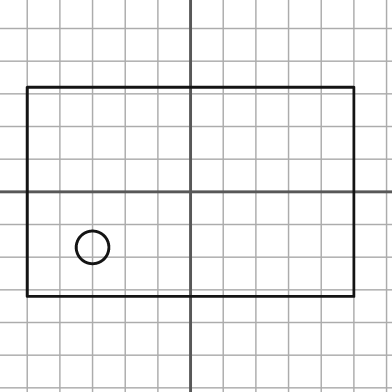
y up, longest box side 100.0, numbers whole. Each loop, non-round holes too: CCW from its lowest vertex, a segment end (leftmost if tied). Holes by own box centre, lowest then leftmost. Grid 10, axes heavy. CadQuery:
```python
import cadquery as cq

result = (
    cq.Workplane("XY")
    .moveTo(-50.0, -32.0)
    .lineTo(50.0, -32.0)
    .lineTo(50.0, 32.0)
    .lineTo(-50.0, 32.0)
    .close()
    .moveTo(-30.0, -17.0)
    .circle(5.0)
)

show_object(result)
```